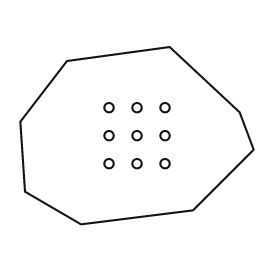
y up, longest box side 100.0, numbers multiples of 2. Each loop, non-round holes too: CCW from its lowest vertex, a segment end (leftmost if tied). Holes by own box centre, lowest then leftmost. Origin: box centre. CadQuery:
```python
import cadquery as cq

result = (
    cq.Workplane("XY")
    .moveTo(-24.0, -38.0)
    .lineTo(24.0, -32.0)
    .lineTo(50.0, -6.0)
    .lineTo(44.0, 10.0)
    .lineTo(14.0, 38.0)
    .lineTo(-30.0, 32.0)
    .lineTo(-50.0, 6.0)
    .lineTo(-48.0, -24.0)
    .close()
    .moveTo(-12.0, -12.0)
    .circle(2.0)
    .moveTo(0.0, -12.0)
    .circle(2.0)
    .moveTo(12.0, -12.0)
    .circle(2.0)
    .moveTo(-12.0, 0.0)
    .circle(2.0)
    .moveTo(0.0, 0.0)
    .circle(2.0)
    .moveTo(12.0, 0.0)
    .circle(2.0)
    .moveTo(-12.0, 12.0)
    .circle(2.0)
    .moveTo(0.0, 12.0)
    .circle(2.0)
    .moveTo(12.0, 12.0)
    .circle(2.0)
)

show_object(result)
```